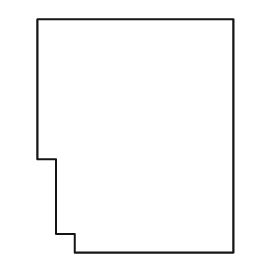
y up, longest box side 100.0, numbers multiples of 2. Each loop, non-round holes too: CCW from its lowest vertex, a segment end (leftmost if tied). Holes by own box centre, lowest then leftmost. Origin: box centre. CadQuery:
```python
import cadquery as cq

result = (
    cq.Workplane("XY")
    .moveTo(-26.0, -50.0)
    .lineTo(42.0, -50.0)
    .lineTo(42.0, 50.0)
    .lineTo(-42.0, 50.0)
    .lineTo(-42.0, -10.0)
    .lineTo(-34.0, -10.0)
    .lineTo(-34.0, -42.0)
    .lineTo(-26.0, -42.0)
    .close()
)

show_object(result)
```